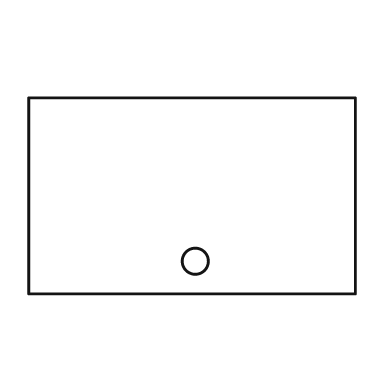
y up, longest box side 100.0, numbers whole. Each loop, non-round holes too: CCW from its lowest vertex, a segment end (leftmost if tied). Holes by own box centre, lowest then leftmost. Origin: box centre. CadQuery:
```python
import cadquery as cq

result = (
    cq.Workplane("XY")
    .moveTo(-50.0, -30.0)
    .lineTo(50.0, -30.0)
    .lineTo(50.0, 30.0)
    .lineTo(-50.0, 30.0)
    .close()
    .moveTo(1.0, -20.0)
    .circle(4.0)
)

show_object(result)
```